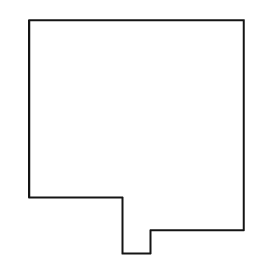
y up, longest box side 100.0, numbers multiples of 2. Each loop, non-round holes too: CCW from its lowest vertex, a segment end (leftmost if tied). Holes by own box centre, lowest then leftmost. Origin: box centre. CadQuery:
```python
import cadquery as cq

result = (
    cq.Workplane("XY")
    .moveTo(-6.0, -50.0)
    .lineTo(6.0, -50.0)
    .lineTo(6.0, -40.0)
    .lineTo(46.0, -40.0)
    .lineTo(46.0, 50.0)
    .lineTo(-46.0, 50.0)
    .lineTo(-46.0, -26.0)
    .lineTo(-6.0, -26.0)
    .close()
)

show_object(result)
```